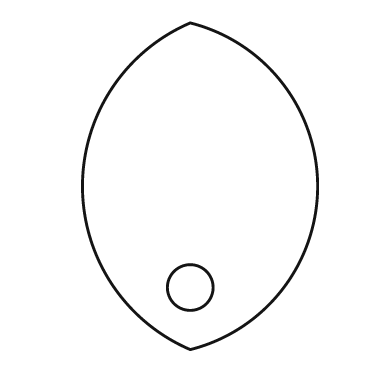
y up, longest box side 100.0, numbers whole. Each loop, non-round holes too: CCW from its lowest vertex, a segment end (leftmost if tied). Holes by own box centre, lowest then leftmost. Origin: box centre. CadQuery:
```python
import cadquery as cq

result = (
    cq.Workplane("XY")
    .moveTo(-3.0, -50.0)
    .threePointArc((36.0, 0.0), (-3.0, 50.0))
    .threePointArc((-36.0, 0.0), (-3.0, -50.0))
    .close()
    .moveTo(-3.0, -31.0)
    .circle(7.0)
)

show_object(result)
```